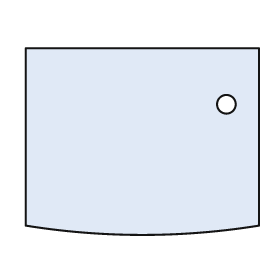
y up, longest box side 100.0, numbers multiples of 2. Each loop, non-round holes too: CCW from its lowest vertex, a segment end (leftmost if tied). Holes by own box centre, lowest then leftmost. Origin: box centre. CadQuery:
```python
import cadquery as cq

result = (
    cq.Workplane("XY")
    .moveTo(-50.0, -36.0)
    .threePointArc((0.0, -40.0), (50.0, -36.0))
    .lineTo(50.0, 40.0)
    .lineTo(-50.0, 40.0)
    .close()
    .moveTo(36.0, 16.0)
    .circle(4.0)
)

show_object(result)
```